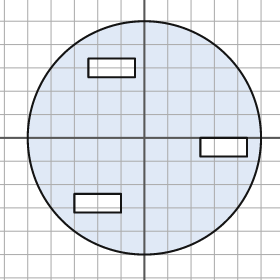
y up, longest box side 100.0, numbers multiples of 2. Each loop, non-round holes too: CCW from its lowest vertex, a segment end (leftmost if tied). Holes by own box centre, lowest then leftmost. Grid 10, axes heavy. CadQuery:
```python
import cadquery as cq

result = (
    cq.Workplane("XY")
    .moveTo(0.0, 0.0)
    .circle(50.0)
    .moveTo(-30.0, -32.0)
    .lineTo(-10.0, -32.0)
    .lineTo(-10.0, -24.0)
    .lineTo(-30.0, -24.0)
    .close()
    .moveTo(24.0, -8.0)
    .lineTo(44.0, -8.0)
    .lineTo(44.0, 0.0)
    .lineTo(24.0, 0.0)
    .close()
    .moveTo(-24.0, 26.0)
    .lineTo(-4.0, 26.0)
    .lineTo(-4.0, 34.0)
    .lineTo(-24.0, 34.0)
    .close()
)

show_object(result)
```